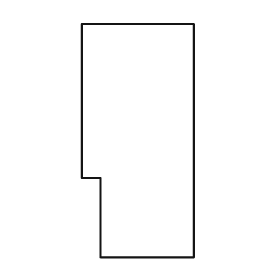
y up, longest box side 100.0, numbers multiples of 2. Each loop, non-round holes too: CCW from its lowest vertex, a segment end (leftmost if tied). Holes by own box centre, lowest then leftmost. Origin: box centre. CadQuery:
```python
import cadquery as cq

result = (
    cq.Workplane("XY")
    .moveTo(-16.0, -50.0)
    .lineTo(24.0, -50.0)
    .lineTo(24.0, 50.0)
    .lineTo(-24.0, 50.0)
    .lineTo(-24.0, -16.0)
    .lineTo(-16.0, -16.0)
    .close()
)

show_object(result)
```